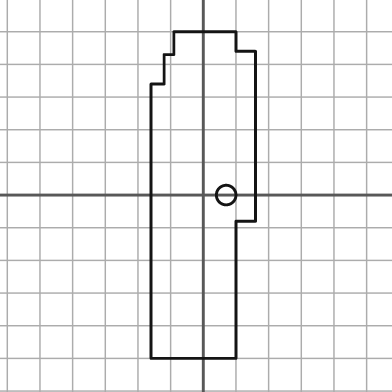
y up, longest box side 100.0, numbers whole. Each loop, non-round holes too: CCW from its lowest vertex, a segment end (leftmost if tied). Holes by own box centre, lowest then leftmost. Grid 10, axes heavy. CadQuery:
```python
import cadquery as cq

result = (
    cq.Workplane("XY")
    .moveTo(-16.0, -50.0)
    .lineTo(10.0, -50.0)
    .lineTo(10.0, -8.0)
    .lineTo(16.0, -8.0)
    .lineTo(16.0, 44.0)
    .lineTo(10.0, 44.0)
    .lineTo(10.0, 50.0)
    .lineTo(-9.0, 50.0)
    .lineTo(-9.0, 43.0)
    .lineTo(-12.0, 43.0)
    .lineTo(-12.0, 34.0)
    .lineTo(-16.0, 34.0)
    .close()
    .moveTo(7.0, 0.0)
    .circle(3.0)
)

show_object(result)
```